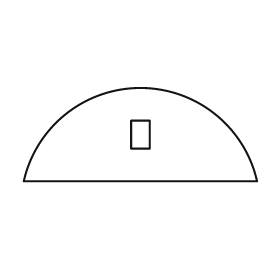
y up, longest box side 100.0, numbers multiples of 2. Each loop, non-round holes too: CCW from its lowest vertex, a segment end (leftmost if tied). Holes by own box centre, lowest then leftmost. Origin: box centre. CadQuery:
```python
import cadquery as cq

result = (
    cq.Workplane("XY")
    .moveTo(-50.0, -20.0)
    .lineTo(50.0, -20.0)
    .threePointArc((0.0, 20.0), (-50.0, -20.0))
    .close()
    .moveTo(-4.0, -6.0)
    .lineTo(4.0, -6.0)
    .lineTo(4.0, 6.0)
    .lineTo(-4.0, 6.0)
    .close()
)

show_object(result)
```